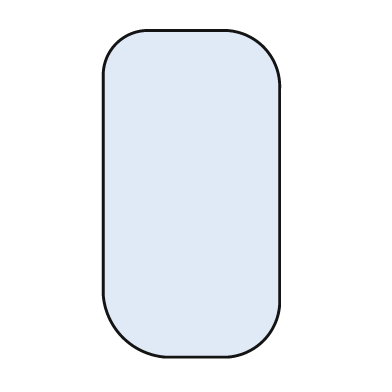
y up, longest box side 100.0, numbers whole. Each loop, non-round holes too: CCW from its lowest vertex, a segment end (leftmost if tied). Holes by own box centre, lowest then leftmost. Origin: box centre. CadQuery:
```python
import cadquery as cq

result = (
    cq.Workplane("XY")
    .moveTo(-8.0, -50.0)
    .lineTo(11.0, -50.0)
    .threePointArc((22.0, -45.0), (27.0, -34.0))
    .lineTo(27.0, 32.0)
    .threePointArc((22.0, 45.0), (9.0, 50.0))
    .lineTo(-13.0, 50.0)
    .threePointArc((-23.0, 46.0), (-27.0, 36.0))
    .lineTo(-27.0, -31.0)
    .threePointArc((-21.0, -44.0), (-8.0, -50.0))
    .close()
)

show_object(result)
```